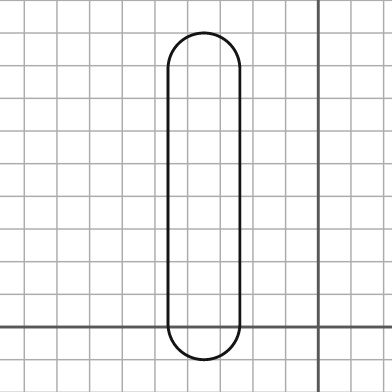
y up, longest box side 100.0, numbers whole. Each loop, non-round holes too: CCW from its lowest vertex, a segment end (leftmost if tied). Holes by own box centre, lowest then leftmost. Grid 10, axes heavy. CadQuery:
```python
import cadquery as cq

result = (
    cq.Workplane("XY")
    .moveTo(-46.0, 1.0)
    .threePointArc((-35.0, -10.0), (-24.0, 1.0))
    .lineTo(-24.0, 79.0)
    .threePointArc((-35.0, 90.0), (-46.0, 79.0))
    .close()
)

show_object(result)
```